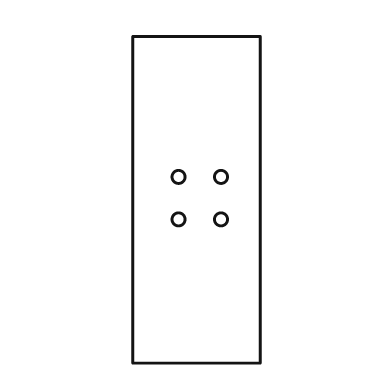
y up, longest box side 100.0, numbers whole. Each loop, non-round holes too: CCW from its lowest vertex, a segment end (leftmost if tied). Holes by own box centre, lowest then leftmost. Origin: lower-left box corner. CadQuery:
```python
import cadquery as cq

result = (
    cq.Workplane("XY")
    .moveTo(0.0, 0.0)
    .lineTo(39.0, 0.0)
    .lineTo(39.0, 100.0)
    .lineTo(0.0, 100.0)
    .close()
    .moveTo(14.0, 44.0)
    .circle(2.0)
    .moveTo(27.0, 44.0)
    .circle(2.0)
    .moveTo(14.0, 57.0)
    .circle(2.0)
    .moveTo(27.0, 57.0)
    .circle(2.0)
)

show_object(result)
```